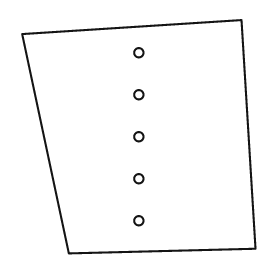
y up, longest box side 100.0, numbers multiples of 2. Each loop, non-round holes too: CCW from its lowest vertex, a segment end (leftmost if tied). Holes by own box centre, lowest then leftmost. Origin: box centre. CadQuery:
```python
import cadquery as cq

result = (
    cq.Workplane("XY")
    .moveTo(-30.0, -50.0)
    .lineTo(50.0, -48.0)
    .lineTo(44.0, 50.0)
    .lineTo(-50.0, 44.0)
    .close()
    .moveTo(0.0, -36.0)
    .circle(2.0)
    .moveTo(0.0, -18.0)
    .circle(2.0)
    .moveTo(0.0, 0.0)
    .circle(2.0)
    .moveTo(0.0, 18.0)
    .circle(2.0)
    .moveTo(0.0, 36.0)
    .circle(2.0)
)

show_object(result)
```